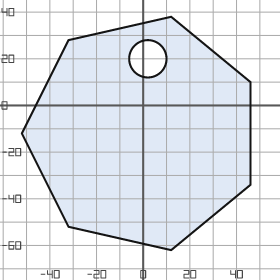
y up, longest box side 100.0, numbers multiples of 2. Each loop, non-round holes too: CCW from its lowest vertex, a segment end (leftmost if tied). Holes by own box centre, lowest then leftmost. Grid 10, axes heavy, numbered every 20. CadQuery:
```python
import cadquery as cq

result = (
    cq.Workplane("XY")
    .moveTo(12.0, -62.0)
    .lineTo(46.0, -34.0)
    .lineTo(46.0, 10.0)
    .lineTo(12.0, 38.0)
    .lineTo(-32.0, 28.0)
    .lineTo(-52.0, -12.0)
    .lineTo(-32.0, -52.0)
    .close()
    .moveTo(2.0, 20.0)
    .circle(8.0)
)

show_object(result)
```